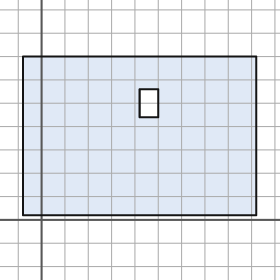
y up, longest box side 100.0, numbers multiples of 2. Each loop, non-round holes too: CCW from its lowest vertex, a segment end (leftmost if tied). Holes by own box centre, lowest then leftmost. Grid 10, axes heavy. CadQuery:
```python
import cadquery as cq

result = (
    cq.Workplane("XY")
    .moveTo(-8.0, 2.0)
    .lineTo(92.0, 2.0)
    .lineTo(92.0, 70.0)
    .lineTo(-8.0, 70.0)
    .close()
    .moveTo(42.0, 44.0)
    .lineTo(50.0, 44.0)
    .lineTo(50.0, 56.0)
    .lineTo(42.0, 56.0)
    .close()
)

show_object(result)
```